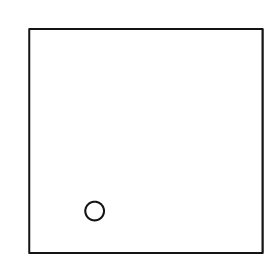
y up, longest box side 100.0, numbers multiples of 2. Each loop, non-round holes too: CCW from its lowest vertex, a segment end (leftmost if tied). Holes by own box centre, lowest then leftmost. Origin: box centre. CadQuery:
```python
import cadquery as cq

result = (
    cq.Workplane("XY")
    .moveTo(-50.0, -48.0)
    .lineTo(50.0, -48.0)
    .lineTo(50.0, 48.0)
    .lineTo(-50.0, 48.0)
    .close()
    .moveTo(-22.0, -30.0)
    .circle(4.0)
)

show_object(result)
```